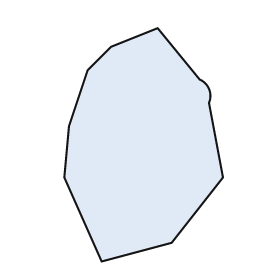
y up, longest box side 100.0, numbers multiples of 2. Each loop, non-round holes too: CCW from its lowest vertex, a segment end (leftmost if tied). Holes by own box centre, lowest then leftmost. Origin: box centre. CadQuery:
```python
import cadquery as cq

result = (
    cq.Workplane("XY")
    .moveTo(-18.0, -50.0)
    .lineTo(12.0, -42.0)
    .lineTo(34.0, -14.0)
    .lineTo(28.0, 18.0)
    .threePointArc((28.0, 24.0), (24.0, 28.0))
    .lineTo(6.0, 50.0)
    .lineTo(-14.0, 42.0)
    .lineTo(-24.0, 32.0)
    .lineTo(-32.0, 8.0)
    .lineTo(-34.0, -14.0)
    .close()
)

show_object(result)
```